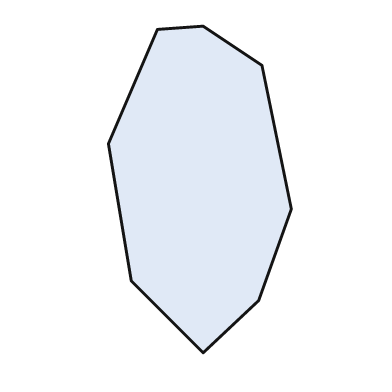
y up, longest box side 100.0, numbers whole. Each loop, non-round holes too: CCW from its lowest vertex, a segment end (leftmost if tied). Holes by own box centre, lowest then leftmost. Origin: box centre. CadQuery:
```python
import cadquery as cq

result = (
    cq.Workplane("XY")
    .moveTo(1.0, -50.0)
    .lineTo(18.0, -34.0)
    .lineTo(28.0, -6.0)
    .lineTo(19.0, 38.0)
    .lineTo(1.0, 50.0)
    .lineTo(-13.0, 49.0)
    .lineTo(-28.0, 14.0)
    .lineTo(-21.0, -28.0)
    .close()
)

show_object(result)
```